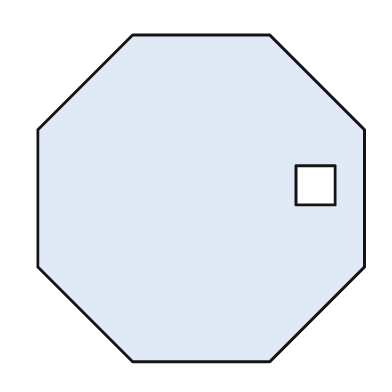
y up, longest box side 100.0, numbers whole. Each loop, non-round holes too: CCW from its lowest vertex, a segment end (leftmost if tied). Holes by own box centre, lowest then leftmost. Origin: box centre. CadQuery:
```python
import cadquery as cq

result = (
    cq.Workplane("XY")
    .moveTo(-21.0, -50.0)
    .lineTo(21.0, -50.0)
    .lineTo(50.0, -21.0)
    .lineTo(50.0, 21.0)
    .lineTo(21.0, 50.0)
    .lineTo(-21.0, 50.0)
    .lineTo(-50.0, 21.0)
    .lineTo(-50.0, -21.0)
    .close()
    .moveTo(29.0, -2.0)
    .lineTo(41.0, -2.0)
    .lineTo(41.0, 10.0)
    .lineTo(29.0, 10.0)
    .close()
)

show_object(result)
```